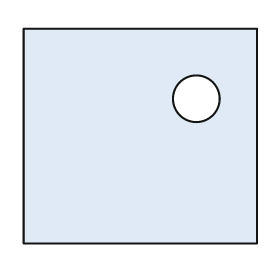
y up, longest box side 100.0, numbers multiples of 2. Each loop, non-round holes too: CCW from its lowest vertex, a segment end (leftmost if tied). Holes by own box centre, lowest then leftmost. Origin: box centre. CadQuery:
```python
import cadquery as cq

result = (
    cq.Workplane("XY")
    .moveTo(-50.0, -46.0)
    .lineTo(50.0, -46.0)
    .lineTo(50.0, 46.0)
    .lineTo(-50.0, 46.0)
    .close()
    .moveTo(24.0, 16.0)
    .circle(10.0)
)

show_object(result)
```